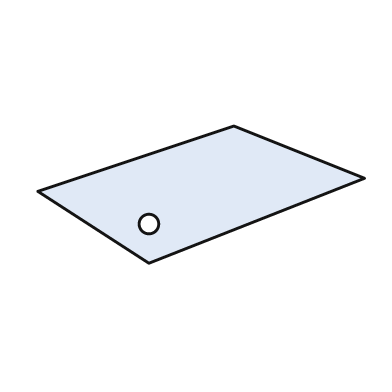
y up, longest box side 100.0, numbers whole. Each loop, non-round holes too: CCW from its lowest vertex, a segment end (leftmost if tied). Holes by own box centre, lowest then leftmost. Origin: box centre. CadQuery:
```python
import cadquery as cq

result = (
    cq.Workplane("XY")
    .moveTo(-16.0, -21.0)
    .lineTo(50.0, 5.0)
    .lineTo(10.0, 21.0)
    .lineTo(-50.0, 1.0)
    .close()
    .moveTo(-16.0, -9.0)
    .circle(3.0)
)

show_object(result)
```